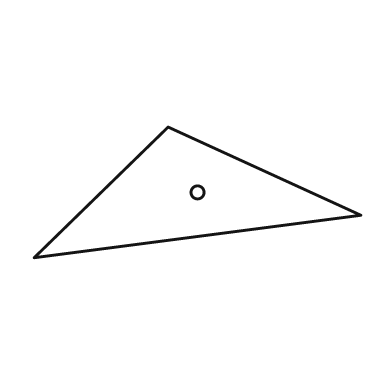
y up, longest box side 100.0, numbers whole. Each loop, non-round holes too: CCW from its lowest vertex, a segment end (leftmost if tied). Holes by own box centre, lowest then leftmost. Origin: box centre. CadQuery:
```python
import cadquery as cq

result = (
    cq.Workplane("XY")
    .moveTo(-50.0, -20.0)
    .lineTo(50.0, -7.0)
    .lineTo(-9.0, 20.0)
    .close()
    .moveTo(0.0, 0.0)
    .circle(2.0)
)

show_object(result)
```